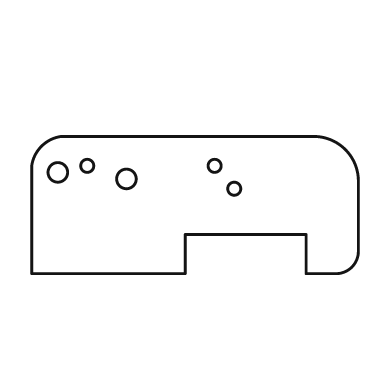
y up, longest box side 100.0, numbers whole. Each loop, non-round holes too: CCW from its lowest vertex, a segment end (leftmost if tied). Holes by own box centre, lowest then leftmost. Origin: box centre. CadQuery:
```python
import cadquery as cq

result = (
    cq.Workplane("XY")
    .moveTo(-50.0, -21.0)
    .lineTo(-3.0, -21.0)
    .lineTo(-3.0, -9.0)
    .lineTo(34.0, -9.0)
    .lineTo(34.0, -21.0)
    .lineTo(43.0, -21.0)
    .threePointArc((48.0, -19.0), (50.0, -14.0))
    .lineTo(50.0, 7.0)
    .threePointArc((46.0, 17.0), (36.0, 21.0))
    .lineTo(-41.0, 21.0)
    .threePointArc((-47.0, 18.0), (-50.0, 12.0))
    .close()
    .moveTo(12.0, 5.0)
    .circle(2.0)
    .moveTo(-21.0, 8.0)
    .circle(3.0)
    .moveTo(-42.0, 10.0)
    .circle(3.0)
    .moveTo(-33.0, 12.0)
    .circle(2.0)
    .moveTo(6.0, 12.0)
    .circle(2.0)
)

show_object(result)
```